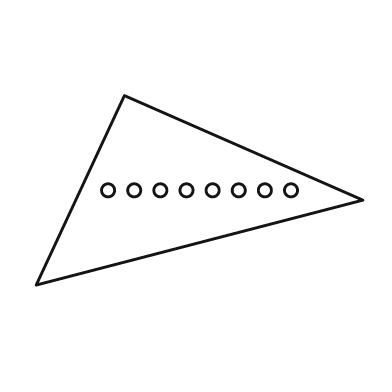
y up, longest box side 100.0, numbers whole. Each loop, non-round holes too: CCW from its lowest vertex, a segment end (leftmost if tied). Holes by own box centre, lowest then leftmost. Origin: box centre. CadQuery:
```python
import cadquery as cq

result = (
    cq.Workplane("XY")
    .moveTo(-50.0, -29.0)
    .lineTo(50.0, -3.0)
    .lineTo(-23.0, 29.0)
    .close()
    .moveTo(-28.0, 0.0)
    .circle(2.0)
    .moveTo(-20.0, 0.0)
    .circle(2.0)
    .moveTo(-12.0, 0.0)
    .circle(2.0)
    .moveTo(-4.0, 0.0)
    .circle(2.0)
    .moveTo(4.0, 0.0)
    .circle(2.0)
    .moveTo(12.0, 0.0)
    .circle(2.0)
    .moveTo(20.0, 0.0)
    .circle(2.0)
    .moveTo(28.0, 0.0)
    .circle(2.0)
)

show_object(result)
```